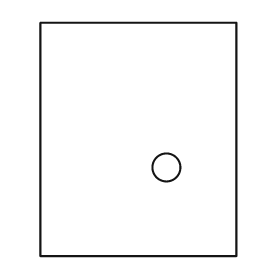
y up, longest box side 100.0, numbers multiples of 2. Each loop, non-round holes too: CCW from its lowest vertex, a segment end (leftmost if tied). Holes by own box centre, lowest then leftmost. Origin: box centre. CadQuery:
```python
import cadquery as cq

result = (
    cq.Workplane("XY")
    .moveTo(-42.0, -50.0)
    .lineTo(42.0, -50.0)
    .lineTo(42.0, 50.0)
    .lineTo(-42.0, 50.0)
    .close()
    .moveTo(12.0, -12.0)
    .circle(6.0)
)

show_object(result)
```